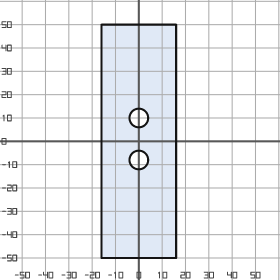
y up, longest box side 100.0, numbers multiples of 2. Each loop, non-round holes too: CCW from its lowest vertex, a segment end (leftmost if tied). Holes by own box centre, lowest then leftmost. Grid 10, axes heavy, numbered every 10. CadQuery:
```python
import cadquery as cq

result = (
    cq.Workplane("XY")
    .moveTo(-16.0, -50.0)
    .lineTo(16.0, -50.0)
    .lineTo(16.0, 50.0)
    .lineTo(-16.0, 50.0)
    .close()
    .moveTo(0.0, -8.0)
    .circle(4.0)
    .moveTo(0.0, 10.0)
    .circle(4.0)
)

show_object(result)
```